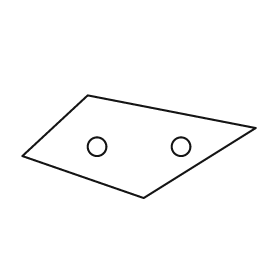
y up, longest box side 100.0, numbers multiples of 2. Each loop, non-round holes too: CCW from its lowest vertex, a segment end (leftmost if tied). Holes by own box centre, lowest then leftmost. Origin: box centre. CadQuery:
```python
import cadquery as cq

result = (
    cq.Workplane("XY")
    .moveTo(2.0, -22.0)
    .lineTo(50.0, 8.0)
    .lineTo(-22.0, 22.0)
    .lineTo(-50.0, -4.0)
    .close()
    .moveTo(-18.0, 0.0)
    .circle(4.0)
    .moveTo(18.0, 0.0)
    .circle(4.0)
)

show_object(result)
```